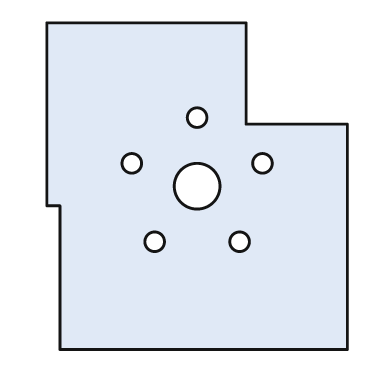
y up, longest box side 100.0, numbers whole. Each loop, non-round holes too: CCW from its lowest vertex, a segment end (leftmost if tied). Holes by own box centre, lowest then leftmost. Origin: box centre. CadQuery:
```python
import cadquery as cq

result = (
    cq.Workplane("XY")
    .moveTo(-42.0, -50.0)
    .lineTo(46.0, -50.0)
    .lineTo(46.0, 19.0)
    .lineTo(15.0, 19.0)
    .lineTo(15.0, 50.0)
    .lineTo(-46.0, 50.0)
    .lineTo(-46.0, -6.0)
    .lineTo(-42.0, -6.0)
    .close()
    .moveTo(-13.0, -17.0)
    .circle(3.0)
    .moveTo(13.0, -17.0)
    .circle(3.0)
    .moveTo(0.0, 0.0)
    .circle(7.0)
    .moveTo(-20.0, 7.0)
    .circle(3.0)
    .moveTo(20.0, 7.0)
    .circle(3.0)
    .moveTo(0.0, 21.0)
    .circle(3.0)
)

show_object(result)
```